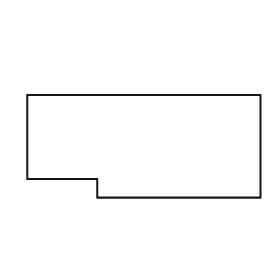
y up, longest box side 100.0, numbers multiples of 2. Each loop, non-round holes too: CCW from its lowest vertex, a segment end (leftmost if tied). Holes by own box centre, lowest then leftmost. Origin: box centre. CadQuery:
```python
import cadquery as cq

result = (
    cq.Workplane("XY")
    .moveTo(-20.0, -22.0)
    .lineTo(50.0, -22.0)
    .lineTo(50.0, 22.0)
    .lineTo(-50.0, 22.0)
    .lineTo(-50.0, -14.0)
    .lineTo(-20.0, -14.0)
    .close()
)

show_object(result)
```